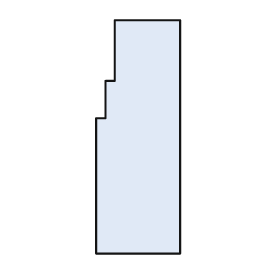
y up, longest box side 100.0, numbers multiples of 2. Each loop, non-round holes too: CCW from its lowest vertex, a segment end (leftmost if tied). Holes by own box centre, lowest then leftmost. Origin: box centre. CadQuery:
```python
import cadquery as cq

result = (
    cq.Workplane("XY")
    .moveTo(-18.0, -50.0)
    .lineTo(18.0, -50.0)
    .lineTo(18.0, 50.0)
    .lineTo(-10.0, 50.0)
    .lineTo(-10.0, 24.0)
    .lineTo(-14.0, 24.0)
    .lineTo(-14.0, 8.0)
    .lineTo(-18.0, 8.0)
    .close()
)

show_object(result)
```